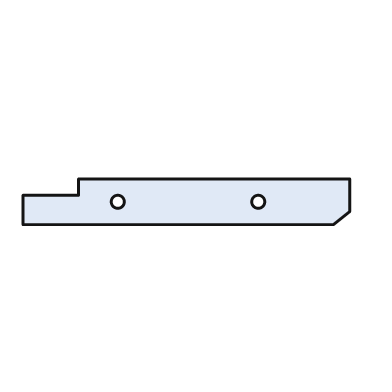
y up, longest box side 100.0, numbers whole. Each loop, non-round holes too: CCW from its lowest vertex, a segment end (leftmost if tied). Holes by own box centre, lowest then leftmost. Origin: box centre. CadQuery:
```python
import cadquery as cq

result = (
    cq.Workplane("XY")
    .moveTo(-50.0, -7.0)
    .lineTo(45.0, -7.0)
    .lineTo(50.0, -3.0)
    .lineTo(50.0, 7.0)
    .lineTo(-33.0, 7.0)
    .lineTo(-33.0, 2.0)
    .lineTo(-50.0, 2.0)
    .close()
    .moveTo(-21.0, 0.0)
    .circle(2.0)
    .moveTo(22.0, 0.0)
    .circle(2.0)
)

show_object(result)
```